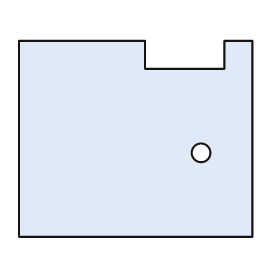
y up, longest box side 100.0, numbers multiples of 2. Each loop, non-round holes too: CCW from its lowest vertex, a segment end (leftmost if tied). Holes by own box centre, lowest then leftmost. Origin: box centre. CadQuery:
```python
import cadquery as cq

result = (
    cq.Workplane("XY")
    .moveTo(-50.0, -42.0)
    .lineTo(50.0, -42.0)
    .lineTo(50.0, 42.0)
    .lineTo(38.0, 42.0)
    .lineTo(38.0, 30.0)
    .lineTo(4.0, 30.0)
    .lineTo(4.0, 42.0)
    .lineTo(-50.0, 42.0)
    .close()
    .moveTo(28.0, -6.0)
    .circle(4.0)
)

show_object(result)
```